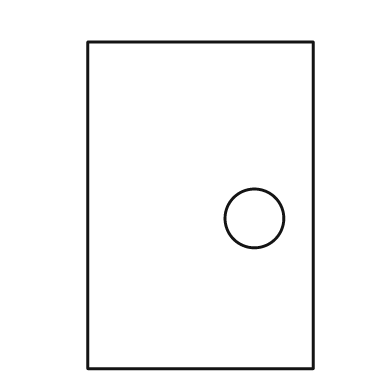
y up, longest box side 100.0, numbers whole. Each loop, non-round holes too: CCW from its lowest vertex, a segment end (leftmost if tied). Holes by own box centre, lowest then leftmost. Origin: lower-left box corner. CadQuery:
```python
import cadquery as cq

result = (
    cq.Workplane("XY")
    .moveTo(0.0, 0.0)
    .lineTo(69.0, 0.0)
    .lineTo(69.0, 100.0)
    .lineTo(0.0, 100.0)
    .close()
    .moveTo(51.0, 46.0)
    .circle(9.0)
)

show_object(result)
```